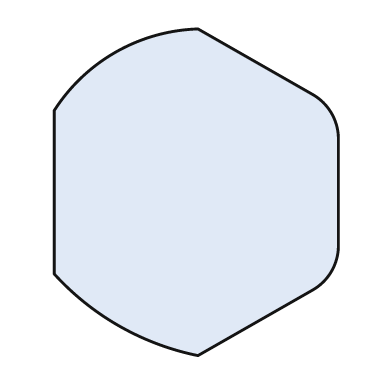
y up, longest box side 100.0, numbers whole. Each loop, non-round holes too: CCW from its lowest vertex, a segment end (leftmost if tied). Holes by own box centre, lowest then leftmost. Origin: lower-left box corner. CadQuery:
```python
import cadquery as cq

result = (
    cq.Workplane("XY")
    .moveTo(44.0, 0.0)
    .lineTo(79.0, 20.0)
    .threePointArc((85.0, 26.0), (87.0, 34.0))
    .lineTo(87.0, 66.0)
    .threePointArc((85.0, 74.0), (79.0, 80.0))
    .lineTo(44.0, 100.0)
    .threePointArc((19.0, 93.0), (0.0, 75.0))
    .lineTo(0.0, 25.0)
    .threePointArc((20.0, 9.0), (44.0, 0.0))
    .close()
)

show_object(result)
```